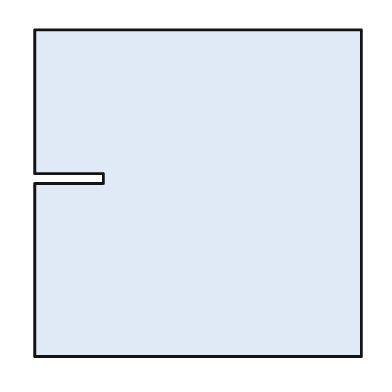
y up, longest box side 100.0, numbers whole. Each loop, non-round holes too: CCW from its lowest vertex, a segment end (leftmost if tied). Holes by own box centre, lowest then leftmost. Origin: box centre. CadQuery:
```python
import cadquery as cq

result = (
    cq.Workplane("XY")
    .moveTo(-50.0, -50.0)
    .lineTo(50.0, -50.0)
    .lineTo(50.0, 50.0)
    .lineTo(-50.0, 50.0)
    .lineTo(-50.0, 6.0)
    .lineTo(-29.0, 6.0)
    .lineTo(-29.0, 3.0)
    .lineTo(-50.0, 3.0)
    .close()
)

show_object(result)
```